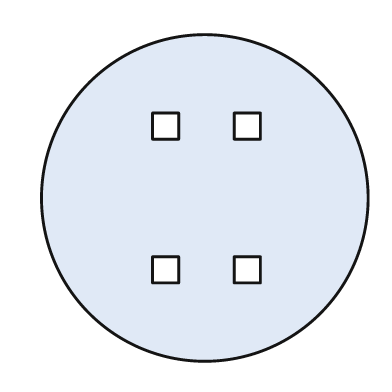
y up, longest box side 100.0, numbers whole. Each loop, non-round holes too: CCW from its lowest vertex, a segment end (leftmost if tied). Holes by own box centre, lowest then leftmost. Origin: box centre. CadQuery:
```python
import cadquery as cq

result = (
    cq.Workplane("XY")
    .moveTo(0.0, 0.0)
    .circle(50.0)
    .moveTo(-16.0, -26.0)
    .lineTo(-8.0, -26.0)
    .lineTo(-8.0, -18.0)
    .lineTo(-16.0, -18.0)
    .close()
    .moveTo(9.0, -26.0)
    .lineTo(17.0, -26.0)
    .lineTo(17.0, -18.0)
    .lineTo(9.0, -18.0)
    .close()
    .moveTo(-16.0, 18.0)
    .lineTo(-8.0, 18.0)
    .lineTo(-8.0, 26.0)
    .lineTo(-16.0, 26.0)
    .close()
    .moveTo(9.0, 18.0)
    .lineTo(17.0, 18.0)
    .lineTo(17.0, 26.0)
    .lineTo(9.0, 26.0)
    .close()
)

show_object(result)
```